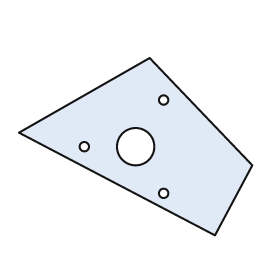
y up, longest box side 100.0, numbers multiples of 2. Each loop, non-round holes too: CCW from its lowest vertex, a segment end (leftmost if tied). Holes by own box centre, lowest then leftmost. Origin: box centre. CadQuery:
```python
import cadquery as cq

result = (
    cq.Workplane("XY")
    .moveTo(34.0, -38.0)
    .lineTo(50.0, -8.0)
    .lineTo(6.0, 38.0)
    .lineTo(-50.0, 6.0)
    .close()
    .moveTo(12.0, -20.0)
    .circle(2.0)
    .moveTo(-22.0, 0.0)
    .circle(2.0)
    .moveTo(0.0, 0.0)
    .circle(8.0)
    .moveTo(12.0, 20.0)
    .circle(2.0)
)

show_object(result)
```